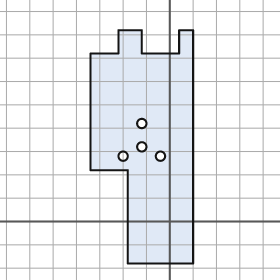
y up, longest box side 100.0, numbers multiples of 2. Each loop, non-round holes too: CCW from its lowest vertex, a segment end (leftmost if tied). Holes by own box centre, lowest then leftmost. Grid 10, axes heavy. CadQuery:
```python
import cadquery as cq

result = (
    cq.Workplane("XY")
    .moveTo(-18.0, -18.0)
    .lineTo(10.0, -18.0)
    .lineTo(10.0, 82.0)
    .lineTo(4.0, 82.0)
    .lineTo(4.0, 72.0)
    .lineTo(-12.0, 72.0)
    .lineTo(-12.0, 82.0)
    .lineTo(-22.0, 82.0)
    .lineTo(-22.0, 72.0)
    .lineTo(-34.0, 72.0)
    .lineTo(-34.0, 22.0)
    .lineTo(-18.0, 22.0)
    .close()
    .moveTo(-20.0, 28.0)
    .circle(2.0)
    .moveTo(-4.0, 28.0)
    .circle(2.0)
    .moveTo(-12.0, 32.0)
    .circle(2.0)
    .moveTo(-12.0, 42.0)
    .circle(2.0)
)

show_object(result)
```